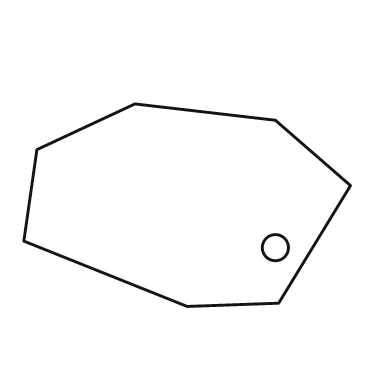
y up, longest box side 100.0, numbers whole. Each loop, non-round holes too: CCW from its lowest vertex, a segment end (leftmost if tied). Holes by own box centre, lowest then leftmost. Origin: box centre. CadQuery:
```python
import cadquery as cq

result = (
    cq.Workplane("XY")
    .moveTo(0.0, -31.0)
    .lineTo(28.0, -30.0)
    .lineTo(50.0, 6.0)
    .lineTo(27.0, 26.0)
    .lineTo(-16.0, 31.0)
    .lineTo(-46.0, 17.0)
    .lineTo(-50.0, -11.0)
    .close()
    .moveTo(27.0, -13.0)
    .circle(4.0)
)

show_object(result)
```